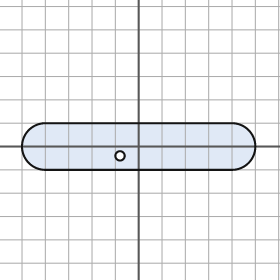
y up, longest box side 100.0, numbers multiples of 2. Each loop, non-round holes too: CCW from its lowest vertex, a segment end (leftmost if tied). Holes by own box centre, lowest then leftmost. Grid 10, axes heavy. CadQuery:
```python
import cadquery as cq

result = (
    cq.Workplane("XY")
    .moveTo(-40.0, -10.0)
    .lineTo(40.0, -10.0)
    .threePointArc((50.0, 0.0), (40.0, 10.0))
    .lineTo(-40.0, 10.0)
    .threePointArc((-50.0, 0.0), (-40.0, -10.0))
    .close()
    .moveTo(-8.0, -4.0)
    .circle(2.0)
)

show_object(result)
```